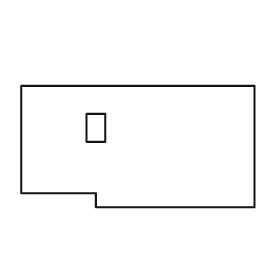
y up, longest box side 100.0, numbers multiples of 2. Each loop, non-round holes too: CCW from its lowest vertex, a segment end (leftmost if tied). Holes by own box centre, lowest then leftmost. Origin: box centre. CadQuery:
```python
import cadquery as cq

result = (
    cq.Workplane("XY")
    .moveTo(-18.0, -26.0)
    .lineTo(50.0, -26.0)
    .lineTo(50.0, 26.0)
    .lineTo(-50.0, 26.0)
    .lineTo(-50.0, -20.0)
    .lineTo(-18.0, -20.0)
    .close()
    .moveTo(-22.0, 2.0)
    .lineTo(-14.0, 2.0)
    .lineTo(-14.0, 14.0)
    .lineTo(-22.0, 14.0)
    .close()
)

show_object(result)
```